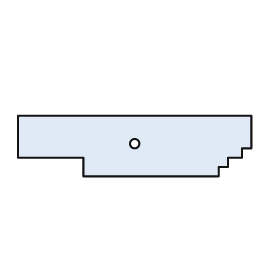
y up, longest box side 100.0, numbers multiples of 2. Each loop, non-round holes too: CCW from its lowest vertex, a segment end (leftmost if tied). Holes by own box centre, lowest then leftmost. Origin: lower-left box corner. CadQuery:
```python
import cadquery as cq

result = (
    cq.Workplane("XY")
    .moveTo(28.0, 0.0)
    .lineTo(86.0, 0.0)
    .lineTo(86.0, 4.0)
    .lineTo(90.0, 4.0)
    .lineTo(90.0, 8.0)
    .lineTo(96.0, 8.0)
    .lineTo(96.0, 12.0)
    .lineTo(100.0, 12.0)
    .lineTo(100.0, 26.0)
    .lineTo(0.0, 26.0)
    .lineTo(0.0, 8.0)
    .lineTo(28.0, 8.0)
    .close()
    .moveTo(50.0, 14.0)
    .circle(2.0)
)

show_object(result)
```